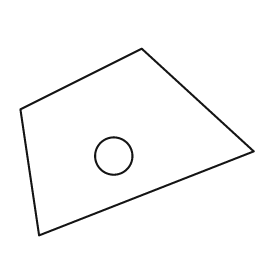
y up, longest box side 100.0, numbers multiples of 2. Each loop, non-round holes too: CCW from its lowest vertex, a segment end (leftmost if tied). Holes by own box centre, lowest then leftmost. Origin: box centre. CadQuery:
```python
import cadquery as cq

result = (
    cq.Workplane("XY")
    .moveTo(-42.0, -40.0)
    .lineTo(50.0, -4.0)
    .lineTo(2.0, 40.0)
    .lineTo(-50.0, 14.0)
    .close()
    .moveTo(-10.0, -6.0)
    .circle(8.0)
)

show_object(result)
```